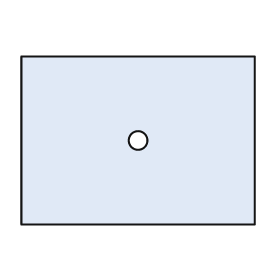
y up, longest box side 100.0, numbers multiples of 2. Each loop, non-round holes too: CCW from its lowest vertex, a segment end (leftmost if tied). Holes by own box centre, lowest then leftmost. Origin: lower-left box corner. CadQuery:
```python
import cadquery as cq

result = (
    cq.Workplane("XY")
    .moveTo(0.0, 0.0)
    .lineTo(100.0, 0.0)
    .lineTo(100.0, 72.0)
    .lineTo(0.0, 72.0)
    .close()
    .moveTo(50.0, 36.0)
    .circle(4.0)
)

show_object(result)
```